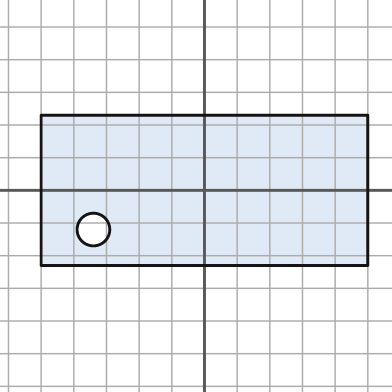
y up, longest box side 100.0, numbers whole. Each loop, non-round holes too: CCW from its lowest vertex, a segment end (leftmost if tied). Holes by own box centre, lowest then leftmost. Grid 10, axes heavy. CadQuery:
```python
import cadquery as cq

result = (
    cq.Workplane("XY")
    .moveTo(-50.0, -23.0)
    .lineTo(50.0, -23.0)
    .lineTo(50.0, 23.0)
    .lineTo(-50.0, 23.0)
    .close()
    .moveTo(-34.0, -12.0)
    .circle(5.0)
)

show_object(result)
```